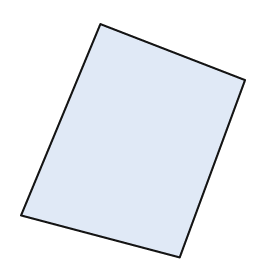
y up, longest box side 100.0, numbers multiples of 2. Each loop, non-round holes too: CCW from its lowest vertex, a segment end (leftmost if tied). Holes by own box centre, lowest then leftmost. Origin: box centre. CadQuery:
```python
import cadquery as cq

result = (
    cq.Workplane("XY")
    .moveTo(20.0, -50.0)
    .lineTo(48.0, 26.0)
    .lineTo(-14.0, 50.0)
    .lineTo(-48.0, -32.0)
    .close()
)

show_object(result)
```